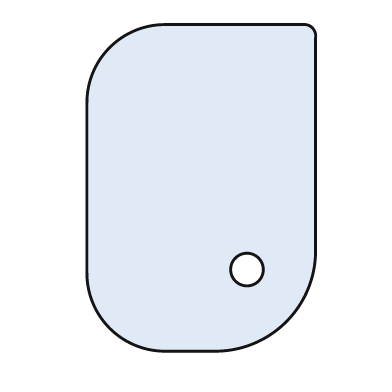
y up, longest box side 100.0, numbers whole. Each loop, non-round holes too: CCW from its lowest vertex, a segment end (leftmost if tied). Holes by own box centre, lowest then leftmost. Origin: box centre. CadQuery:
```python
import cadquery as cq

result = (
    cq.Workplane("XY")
    .moveTo(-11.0, -50.0)
    .lineTo(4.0, -50.0)
    .threePointArc((26.0, -41.0), (35.0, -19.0))
    .lineTo(35.0, 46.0)
    .threePointArc((34.0, 49.0), (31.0, 50.0))
    .lineTo(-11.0, 50.0)
    .threePointArc((-28.0, 43.0), (-35.0, 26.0))
    .lineTo(-35.0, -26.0)
    .threePointArc((-28.0, -43.0), (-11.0, -50.0))
    .close()
    .moveTo(14.0, -25.0)
    .circle(5.0)
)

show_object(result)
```